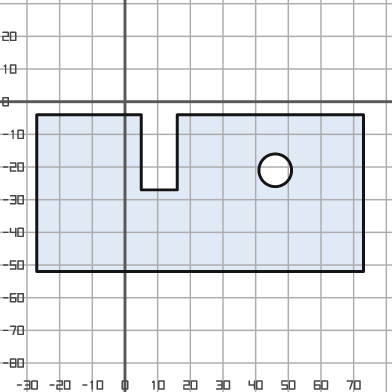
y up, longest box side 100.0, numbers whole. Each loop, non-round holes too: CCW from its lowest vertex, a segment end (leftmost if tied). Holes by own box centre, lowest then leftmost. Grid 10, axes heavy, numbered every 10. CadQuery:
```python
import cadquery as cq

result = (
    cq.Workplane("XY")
    .moveTo(-27.0, -52.0)
    .lineTo(73.0, -52.0)
    .lineTo(73.0, -4.0)
    .lineTo(16.0, -4.0)
    .lineTo(16.0, -27.0)
    .lineTo(5.0, -27.0)
    .lineTo(5.0, -4.0)
    .lineTo(-27.0, -4.0)
    .close()
    .moveTo(46.0, -21.0)
    .circle(5.0)
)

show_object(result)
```